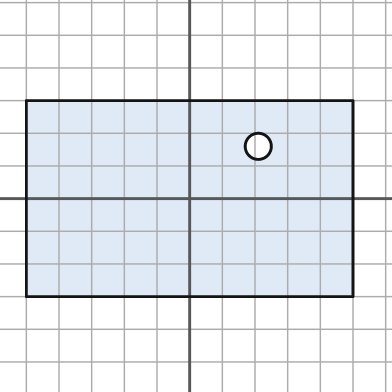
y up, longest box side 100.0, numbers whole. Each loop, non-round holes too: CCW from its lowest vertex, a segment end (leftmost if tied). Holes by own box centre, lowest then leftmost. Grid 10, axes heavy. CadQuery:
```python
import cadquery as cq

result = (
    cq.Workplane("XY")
    .moveTo(-50.0, -30.0)
    .lineTo(50.0, -30.0)
    .lineTo(50.0, 30.0)
    .lineTo(-50.0, 30.0)
    .close()
    .moveTo(21.0, 16.0)
    .circle(4.0)
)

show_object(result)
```